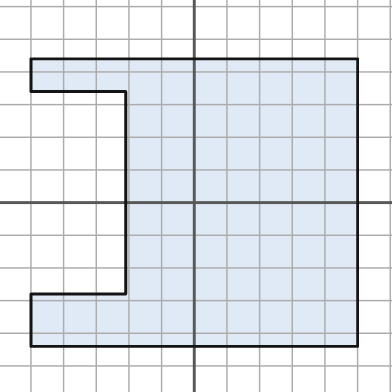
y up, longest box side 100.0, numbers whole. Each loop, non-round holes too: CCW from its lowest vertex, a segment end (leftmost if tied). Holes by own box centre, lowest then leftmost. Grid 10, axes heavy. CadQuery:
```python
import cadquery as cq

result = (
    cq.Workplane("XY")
    .moveTo(-50.0, -44.0)
    .lineTo(50.0, -44.0)
    .lineTo(50.0, 44.0)
    .lineTo(-50.0, 44.0)
    .lineTo(-50.0, 34.0)
    .lineTo(-21.0, 34.0)
    .lineTo(-21.0, -28.0)
    .lineTo(-50.0, -28.0)
    .close()
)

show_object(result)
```